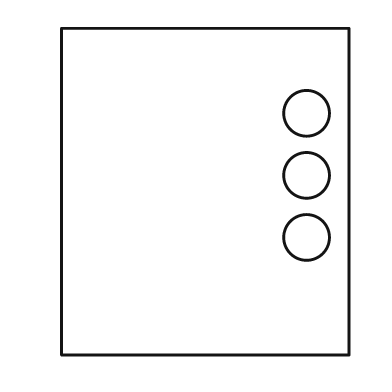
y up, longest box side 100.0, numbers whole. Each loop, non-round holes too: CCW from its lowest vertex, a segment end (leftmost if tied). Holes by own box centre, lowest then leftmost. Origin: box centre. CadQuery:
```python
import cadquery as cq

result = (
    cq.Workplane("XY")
    .moveTo(-44.0, -50.0)
    .lineTo(44.0, -50.0)
    .lineTo(44.0, 50.0)
    .lineTo(-44.0, 50.0)
    .close()
    .moveTo(31.0, -14.0)
    .circle(7.0)
    .moveTo(31.0, 5.0)
    .circle(7.0)
    .moveTo(31.0, 24.0)
    .circle(7.0)
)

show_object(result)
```